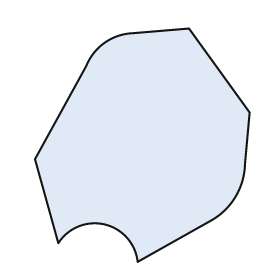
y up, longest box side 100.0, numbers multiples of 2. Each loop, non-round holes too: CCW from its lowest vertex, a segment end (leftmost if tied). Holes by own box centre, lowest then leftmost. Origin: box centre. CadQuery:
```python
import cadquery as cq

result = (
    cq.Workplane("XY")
    .moveTo(-2.0, -50.0)
    .lineTo(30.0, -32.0)
    .threePointArc((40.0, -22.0), (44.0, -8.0))
    .lineTo(46.0, 14.0)
    .lineTo(20.0, 50.0)
    .lineTo(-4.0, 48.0)
    .threePointArc((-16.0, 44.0), (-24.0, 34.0))
    .lineTo(-46.0, -6.0)
    .lineTo(-36.0, -42.0)
    .threePointArc((-16.0, -34.0), (-2.0, -50.0))
    .close()
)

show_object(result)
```